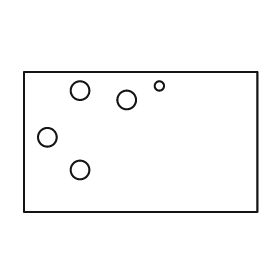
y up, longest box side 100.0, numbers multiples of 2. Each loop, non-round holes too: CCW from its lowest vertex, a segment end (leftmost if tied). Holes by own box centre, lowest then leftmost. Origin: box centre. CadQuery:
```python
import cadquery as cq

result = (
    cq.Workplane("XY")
    .moveTo(-50.0, -30.0)
    .lineTo(50.0, -30.0)
    .lineTo(50.0, 30.0)
    .lineTo(-50.0, 30.0)
    .close()
    .moveTo(-26.0, -12.0)
    .circle(4.0)
    .moveTo(-40.0, 2.0)
    .circle(4.0)
    .moveTo(-6.0, 18.0)
    .circle(4.0)
    .moveTo(-26.0, 22.0)
    .circle(4.0)
    .moveTo(8.0, 24.0)
    .circle(2.0)
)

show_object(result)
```